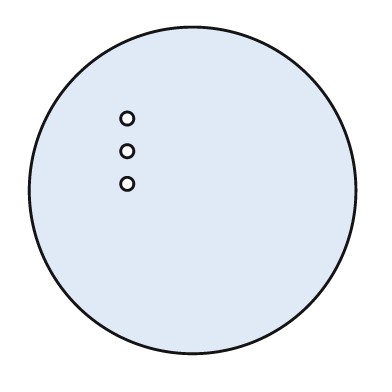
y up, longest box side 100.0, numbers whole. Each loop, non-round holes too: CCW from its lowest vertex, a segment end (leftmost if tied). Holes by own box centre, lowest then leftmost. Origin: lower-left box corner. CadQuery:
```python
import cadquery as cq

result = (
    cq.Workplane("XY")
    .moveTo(50.0, 50.0)
    .circle(50.0)
    .moveTo(30.0, 52.0)
    .circle(2.0)
    .moveTo(30.0, 62.0)
    .circle(2.0)
    .moveTo(30.0, 72.0)
    .circle(2.0)
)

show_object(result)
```